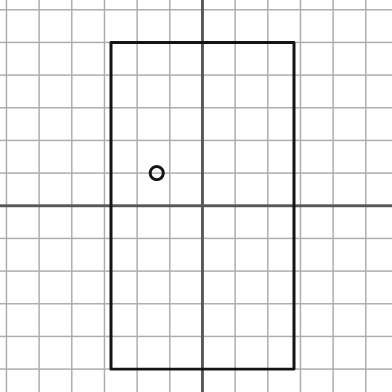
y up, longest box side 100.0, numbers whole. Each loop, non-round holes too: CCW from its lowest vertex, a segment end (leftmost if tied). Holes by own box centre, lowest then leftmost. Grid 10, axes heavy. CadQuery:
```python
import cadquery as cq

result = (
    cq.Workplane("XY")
    .moveTo(-28.0, -50.0)
    .lineTo(28.0, -50.0)
    .lineTo(28.0, 50.0)
    .lineTo(-28.0, 50.0)
    .close()
    .moveTo(-14.0, 10.0)
    .circle(2.0)
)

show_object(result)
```